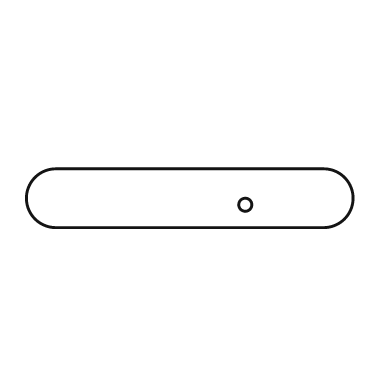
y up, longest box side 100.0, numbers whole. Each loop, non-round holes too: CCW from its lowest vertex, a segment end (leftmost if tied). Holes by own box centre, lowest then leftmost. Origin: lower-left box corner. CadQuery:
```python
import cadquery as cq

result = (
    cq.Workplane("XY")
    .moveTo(9.0, 0.0)
    .lineTo(91.0, 0.0)
    .threePointArc((100.0, 9.0), (91.0, 18.0))
    .lineTo(9.0, 18.0)
    .threePointArc((0.0, 9.0), (9.0, 0.0))
    .close()
    .moveTo(67.0, 7.0)
    .circle(2.0)
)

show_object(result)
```